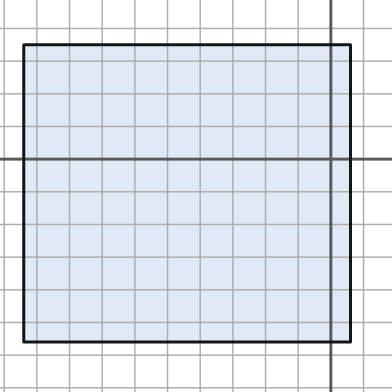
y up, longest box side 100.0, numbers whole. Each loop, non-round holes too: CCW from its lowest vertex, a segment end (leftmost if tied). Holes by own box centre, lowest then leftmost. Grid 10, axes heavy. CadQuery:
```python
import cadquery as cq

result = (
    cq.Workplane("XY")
    .moveTo(-94.0, -56.0)
    .lineTo(6.0, -56.0)
    .lineTo(6.0, 35.0)
    .lineTo(-94.0, 35.0)
    .close()
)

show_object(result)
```